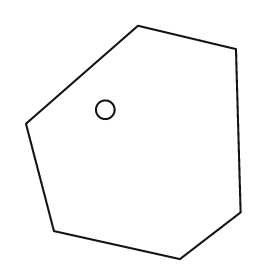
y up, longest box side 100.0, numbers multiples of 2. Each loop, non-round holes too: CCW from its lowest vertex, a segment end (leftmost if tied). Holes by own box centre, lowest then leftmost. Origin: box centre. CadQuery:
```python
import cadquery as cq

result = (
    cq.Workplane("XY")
    .moveTo(20.0, -50.0)
    .lineTo(46.0, -30.0)
    .lineTo(44.0, 40.0)
    .lineTo(2.0, 50.0)
    .lineTo(-46.0, 8.0)
    .lineTo(-34.0, -38.0)
    .close()
    .moveTo(-12.0, 14.0)
    .circle(4.0)
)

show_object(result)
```